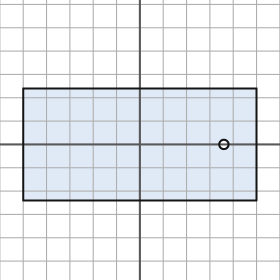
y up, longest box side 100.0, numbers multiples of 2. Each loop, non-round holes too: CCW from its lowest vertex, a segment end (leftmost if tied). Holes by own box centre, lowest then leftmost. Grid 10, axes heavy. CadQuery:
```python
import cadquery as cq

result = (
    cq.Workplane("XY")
    .moveTo(-50.0, -24.0)
    .lineTo(50.0, -24.0)
    .lineTo(50.0, 24.0)
    .lineTo(-50.0, 24.0)
    .close()
    .moveTo(36.0, 0.0)
    .circle(2.0)
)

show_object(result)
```